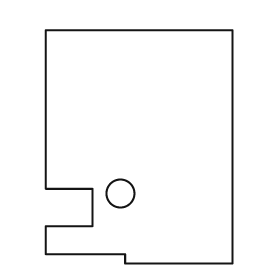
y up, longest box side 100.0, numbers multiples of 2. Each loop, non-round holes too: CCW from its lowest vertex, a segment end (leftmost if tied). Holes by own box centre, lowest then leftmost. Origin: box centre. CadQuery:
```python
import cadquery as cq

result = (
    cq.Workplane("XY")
    .moveTo(-6.0, -50.0)
    .lineTo(40.0, -50.0)
    .lineTo(40.0, 50.0)
    .lineTo(-40.0, 50.0)
    .lineTo(-40.0, -18.0)
    .lineTo(-20.0, -18.0)
    .lineTo(-20.0, -34.0)
    .lineTo(-40.0, -34.0)
    .lineTo(-40.0, -46.0)
    .lineTo(-6.0, -46.0)
    .close()
    .moveTo(-8.0, -20.0)
    .circle(6.0)
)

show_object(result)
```